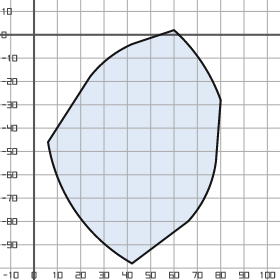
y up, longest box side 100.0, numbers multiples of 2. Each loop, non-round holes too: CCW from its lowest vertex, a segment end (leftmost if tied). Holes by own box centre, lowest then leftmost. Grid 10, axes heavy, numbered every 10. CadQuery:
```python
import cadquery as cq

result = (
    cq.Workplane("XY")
    .moveTo(42.0, -98.0)
    .lineTo(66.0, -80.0)
    .threePointArc((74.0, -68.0), (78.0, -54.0))
    .lineTo(80.0, -28.0)
    .threePointArc((72.0, -12.0), (60.0, 2.0))
    .lineTo(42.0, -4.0)
    .threePointArc((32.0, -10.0), (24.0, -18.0))
    .lineTo(6.0, -46.0)
    .threePointArc((18.0, -76.0), (42.0, -98.0))
    .close()
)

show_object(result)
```